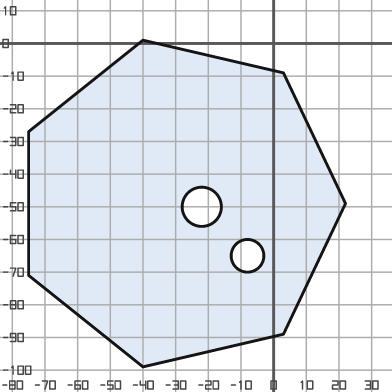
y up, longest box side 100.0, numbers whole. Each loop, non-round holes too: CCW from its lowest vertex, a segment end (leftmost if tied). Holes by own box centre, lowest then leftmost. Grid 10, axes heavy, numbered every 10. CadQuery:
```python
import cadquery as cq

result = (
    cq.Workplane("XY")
    .moveTo(-40.0, -99.0)
    .lineTo(3.0, -89.0)
    .lineTo(22.0, -49.0)
    .lineTo(3.0, -9.0)
    .lineTo(-40.0, 1.0)
    .lineTo(-75.0, -27.0)
    .lineTo(-75.0, -71.0)
    .close()
    .moveTo(-8.0, -65.0)
    .circle(5.0)
    .moveTo(-22.0, -50.0)
    .circle(6.0)
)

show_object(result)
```